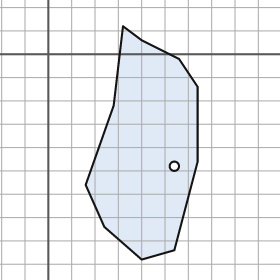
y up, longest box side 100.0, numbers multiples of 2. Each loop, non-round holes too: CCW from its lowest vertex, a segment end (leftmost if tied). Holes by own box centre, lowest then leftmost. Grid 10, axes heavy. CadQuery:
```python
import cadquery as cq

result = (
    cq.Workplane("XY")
    .moveTo(40.0, -88.0)
    .lineTo(54.0, -84.0)
    .lineTo(64.0, -46.0)
    .lineTo(64.0, -14.0)
    .lineTo(56.0, -2.0)
    .lineTo(40.0, 6.0)
    .lineTo(32.0, 12.0)
    .lineTo(28.0, -22.0)
    .lineTo(16.0, -56.0)
    .lineTo(24.0, -74.0)
    .close()
    .moveTo(54.0, -48.0)
    .circle(2.0)
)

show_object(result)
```